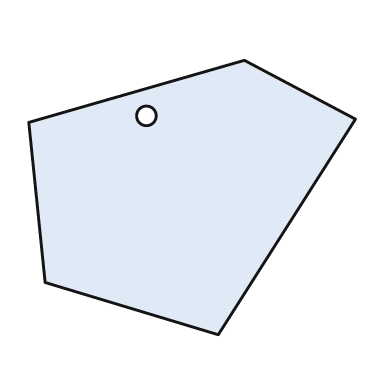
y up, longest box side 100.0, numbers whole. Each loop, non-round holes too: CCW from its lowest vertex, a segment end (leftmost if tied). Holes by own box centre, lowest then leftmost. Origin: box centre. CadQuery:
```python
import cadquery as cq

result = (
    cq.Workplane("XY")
    .moveTo(8.0, -42.0)
    .lineTo(50.0, 24.0)
    .lineTo(16.0, 42.0)
    .lineTo(-50.0, 23.0)
    .lineTo(-45.0, -26.0)
    .close()
    .moveTo(-14.0, 25.0)
    .circle(3.0)
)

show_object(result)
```